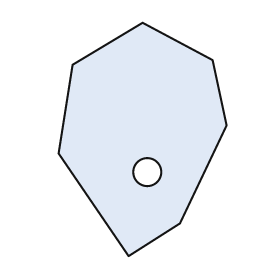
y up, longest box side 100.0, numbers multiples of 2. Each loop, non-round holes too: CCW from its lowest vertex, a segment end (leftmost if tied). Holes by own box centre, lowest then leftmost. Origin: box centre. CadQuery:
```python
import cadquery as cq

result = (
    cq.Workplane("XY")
    .moveTo(-6.0, -50.0)
    .lineTo(16.0, -36.0)
    .lineTo(36.0, 6.0)
    .lineTo(30.0, 34.0)
    .lineTo(0.0, 50.0)
    .lineTo(-30.0, 32.0)
    .lineTo(-36.0, -6.0)
    .close()
    .moveTo(2.0, -14.0)
    .circle(6.0)
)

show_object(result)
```